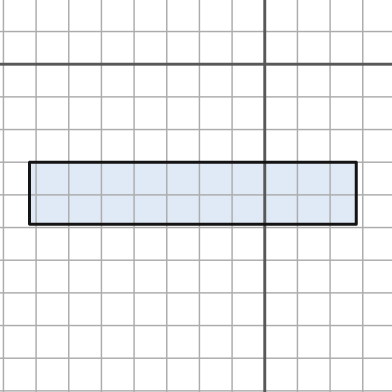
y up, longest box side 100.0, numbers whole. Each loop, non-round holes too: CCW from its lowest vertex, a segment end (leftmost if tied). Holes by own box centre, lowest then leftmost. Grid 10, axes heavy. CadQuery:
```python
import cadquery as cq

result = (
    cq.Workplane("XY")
    .moveTo(-72.0, -49.0)
    .lineTo(28.0, -49.0)
    .lineTo(28.0, -30.0)
    .lineTo(-72.0, -30.0)
    .close()
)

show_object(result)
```